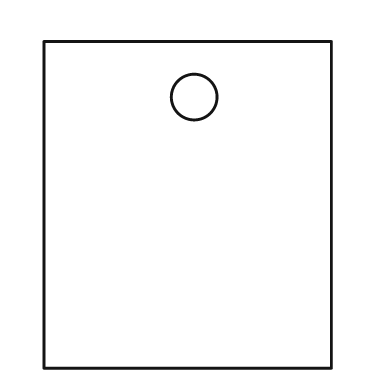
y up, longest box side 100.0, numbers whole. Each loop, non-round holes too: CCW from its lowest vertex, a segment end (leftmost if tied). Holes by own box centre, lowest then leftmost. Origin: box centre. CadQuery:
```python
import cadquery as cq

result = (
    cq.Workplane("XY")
    .moveTo(-44.0, -50.0)
    .lineTo(44.0, -50.0)
    .lineTo(44.0, 50.0)
    .lineTo(-44.0, 50.0)
    .close()
    .moveTo(2.0, 33.0)
    .circle(7.0)
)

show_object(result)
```